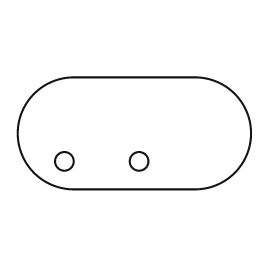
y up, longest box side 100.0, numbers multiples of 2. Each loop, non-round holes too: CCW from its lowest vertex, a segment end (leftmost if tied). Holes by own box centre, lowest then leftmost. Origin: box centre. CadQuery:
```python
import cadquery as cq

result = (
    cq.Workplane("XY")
    .moveTo(-26.0, -24.0)
    .lineTo(26.0, -24.0)
    .threePointArc((50.0, 0.0), (26.0, 24.0))
    .lineTo(-26.0, 24.0)
    .threePointArc((-50.0, 0.0), (-26.0, -24.0))
    .close()
    .moveTo(-30.0, -12.0)
    .circle(4.0)
    .moveTo(2.0, -12.0)
    .circle(4.0)
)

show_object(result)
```